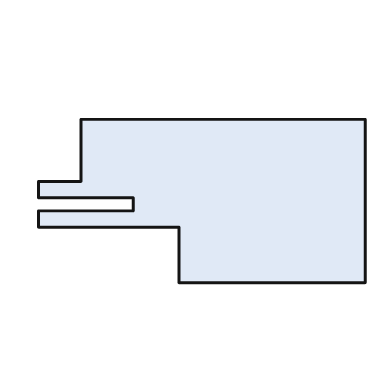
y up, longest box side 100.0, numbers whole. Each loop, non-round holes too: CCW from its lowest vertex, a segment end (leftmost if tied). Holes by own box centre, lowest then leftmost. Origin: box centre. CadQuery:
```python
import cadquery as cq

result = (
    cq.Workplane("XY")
    .moveTo(-7.0, -25.0)
    .lineTo(50.0, -25.0)
    .lineTo(50.0, 25.0)
    .lineTo(-37.0, 25.0)
    .lineTo(-37.0, 6.0)
    .lineTo(-50.0, 6.0)
    .lineTo(-50.0, 1.0)
    .lineTo(-21.0, 1.0)
    .lineTo(-21.0, -3.0)
    .lineTo(-50.0, -3.0)
    .lineTo(-50.0, -8.0)
    .lineTo(-7.0, -8.0)
    .close()
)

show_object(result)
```